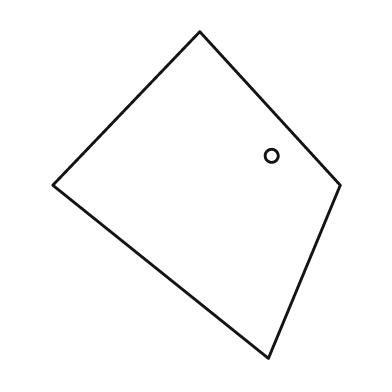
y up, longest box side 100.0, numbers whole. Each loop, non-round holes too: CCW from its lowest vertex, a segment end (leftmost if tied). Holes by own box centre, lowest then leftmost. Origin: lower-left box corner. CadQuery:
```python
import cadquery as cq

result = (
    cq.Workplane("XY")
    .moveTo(66.0, 0.0)
    .lineTo(88.0, 53.0)
    .lineTo(45.0, 100.0)
    .lineTo(0.0, 53.0)
    .close()
    .moveTo(67.0, 62.0)
    .circle(2.0)
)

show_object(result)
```